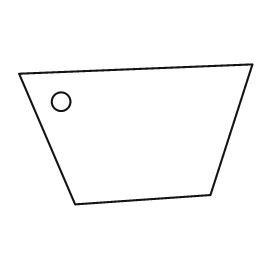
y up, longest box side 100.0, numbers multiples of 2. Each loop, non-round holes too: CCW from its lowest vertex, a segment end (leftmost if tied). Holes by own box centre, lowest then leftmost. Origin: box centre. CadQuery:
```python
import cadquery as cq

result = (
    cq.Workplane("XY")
    .moveTo(-26.0, -30.0)
    .lineTo(32.0, -26.0)
    .lineTo(50.0, 30.0)
    .lineTo(-50.0, 26.0)
    .close()
    .moveTo(-32.0, 14.0)
    .circle(4.0)
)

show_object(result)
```